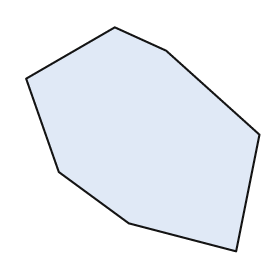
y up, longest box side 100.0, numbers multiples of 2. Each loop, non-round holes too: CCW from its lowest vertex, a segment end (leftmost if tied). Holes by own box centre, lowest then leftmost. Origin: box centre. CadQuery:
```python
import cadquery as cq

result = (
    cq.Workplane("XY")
    .moveTo(40.0, -48.0)
    .lineTo(50.0, 2.0)
    .lineTo(10.0, 38.0)
    .lineTo(-12.0, 48.0)
    .lineTo(-50.0, 26.0)
    .lineTo(-36.0, -14.0)
    .lineTo(-6.0, -36.0)
    .close()
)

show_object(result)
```